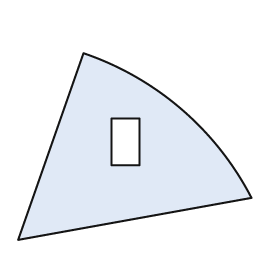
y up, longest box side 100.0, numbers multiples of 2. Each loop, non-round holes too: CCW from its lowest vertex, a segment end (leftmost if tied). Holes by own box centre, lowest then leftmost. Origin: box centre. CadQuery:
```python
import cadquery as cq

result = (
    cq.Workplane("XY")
    .moveTo(-50.0, -40.0)
    .lineTo(50.0, -22.0)
    .threePointArc((20.0, 16.0), (-22.0, 40.0))
    .close()
    .moveTo(-10.0, -8.0)
    .lineTo(2.0, -8.0)
    .lineTo(2.0, 12.0)
    .lineTo(-10.0, 12.0)
    .close()
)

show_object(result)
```